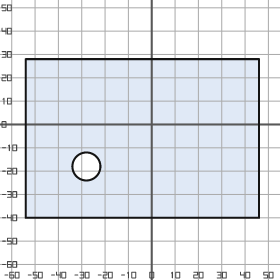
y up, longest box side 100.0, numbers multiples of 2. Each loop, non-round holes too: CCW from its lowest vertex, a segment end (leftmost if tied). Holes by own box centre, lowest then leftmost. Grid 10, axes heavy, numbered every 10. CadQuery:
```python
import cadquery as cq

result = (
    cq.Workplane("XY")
    .moveTo(-54.0, -40.0)
    .lineTo(46.0, -40.0)
    .lineTo(46.0, 28.0)
    .lineTo(-54.0, 28.0)
    .close()
    .moveTo(-28.0, -18.0)
    .circle(6.0)
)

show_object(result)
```